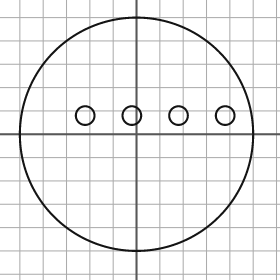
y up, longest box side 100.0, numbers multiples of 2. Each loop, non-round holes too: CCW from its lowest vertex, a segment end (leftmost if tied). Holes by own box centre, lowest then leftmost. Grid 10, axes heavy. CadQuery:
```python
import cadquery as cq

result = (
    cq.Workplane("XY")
    .moveTo(0.0, 0.0)
    .circle(50.0)
    .moveTo(-22.0, 8.0)
    .circle(4.0)
    .moveTo(-2.0, 8.0)
    .circle(4.0)
    .moveTo(18.0, 8.0)
    .circle(4.0)
    .moveTo(38.0, 8.0)
    .circle(4.0)
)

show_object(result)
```